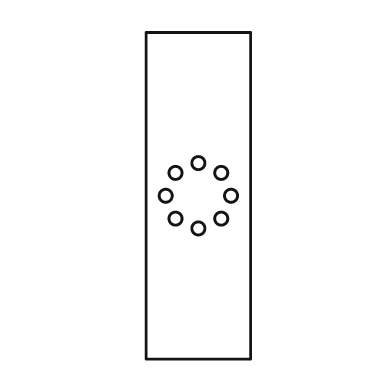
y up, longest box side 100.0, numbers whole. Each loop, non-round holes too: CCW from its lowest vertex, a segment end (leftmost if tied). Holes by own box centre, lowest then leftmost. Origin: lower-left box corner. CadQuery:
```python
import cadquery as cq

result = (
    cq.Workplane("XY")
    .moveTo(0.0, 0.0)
    .lineTo(32.0, 0.0)
    .lineTo(32.0, 100.0)
    .lineTo(0.0, 100.0)
    .close()
    .moveTo(16.0, 40.0)
    .circle(2.0)
    .moveTo(9.0, 43.0)
    .circle(2.0)
    .moveTo(23.0, 43.0)
    .circle(2.0)
    .moveTo(6.0, 50.0)
    .circle(2.0)
    .moveTo(26.0, 50.0)
    .circle(2.0)
    .moveTo(9.0, 57.0)
    .circle(2.0)
    .moveTo(23.0, 57.0)
    .circle(2.0)
    .moveTo(16.0, 60.0)
    .circle(2.0)
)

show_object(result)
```